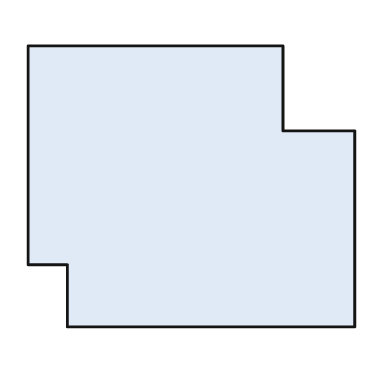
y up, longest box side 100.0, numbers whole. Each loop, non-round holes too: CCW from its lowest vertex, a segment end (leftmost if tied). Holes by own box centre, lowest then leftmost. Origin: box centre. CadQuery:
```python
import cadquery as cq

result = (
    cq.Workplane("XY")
    .moveTo(-38.0, -43.0)
    .lineTo(50.0, -43.0)
    .lineTo(50.0, 17.0)
    .lineTo(28.0, 17.0)
    .lineTo(28.0, 43.0)
    .lineTo(-50.0, 43.0)
    .lineTo(-50.0, -24.0)
    .lineTo(-38.0, -24.0)
    .close()
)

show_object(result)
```